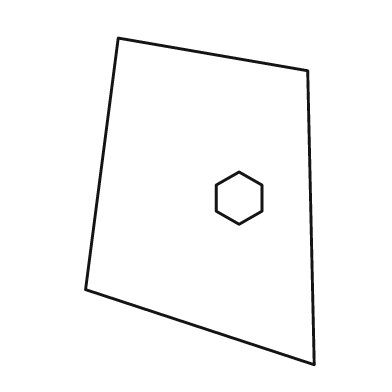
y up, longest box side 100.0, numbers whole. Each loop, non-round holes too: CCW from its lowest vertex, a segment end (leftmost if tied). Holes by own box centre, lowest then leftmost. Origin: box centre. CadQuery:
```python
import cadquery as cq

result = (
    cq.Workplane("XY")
    .moveTo(35.0, -50.0)
    .lineTo(33.0, 40.0)
    .lineTo(-25.0, 50.0)
    .lineTo(-35.0, -27.0)
    .close()
    .moveTo(12.0, -7.0)
    .lineTo(19.0, -3.0)
    .lineTo(19.0, 5.0)
    .lineTo(12.0, 9.0)
    .lineTo(5.0, 5.0)
    .lineTo(5.0, -3.0)
    .close()
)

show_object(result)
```